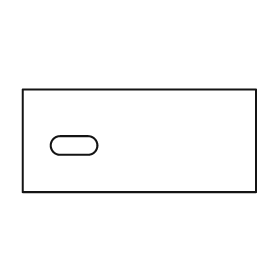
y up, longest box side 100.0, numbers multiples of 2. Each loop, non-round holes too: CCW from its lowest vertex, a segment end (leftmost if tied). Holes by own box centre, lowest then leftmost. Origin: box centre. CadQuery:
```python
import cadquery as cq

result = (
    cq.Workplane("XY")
    .moveTo(-50.0, -22.0)
    .lineTo(50.0, -22.0)
    .lineTo(50.0, 22.0)
    .lineTo(-50.0, 22.0)
    .close()
    .moveTo(-34.0, -6.0)
    .lineTo(-22.0, -6.0)
    .threePointArc((-18.0, -2.0), (-22.0, 2.0))
    .lineTo(-34.0, 2.0)
    .threePointArc((-38.0, -2.0), (-34.0, -6.0))
    .close()
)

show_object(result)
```